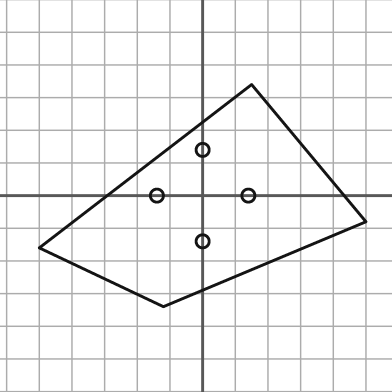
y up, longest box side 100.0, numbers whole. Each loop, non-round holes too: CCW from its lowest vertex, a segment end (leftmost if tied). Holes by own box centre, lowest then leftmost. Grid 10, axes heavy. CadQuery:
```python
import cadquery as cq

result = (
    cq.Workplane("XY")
    .moveTo(-12.0, -34.0)
    .lineTo(50.0, -8.0)
    .lineTo(15.0, 34.0)
    .lineTo(-50.0, -16.0)
    .close()
    .moveTo(0.0, -14.0)
    .circle(2.0)
    .moveTo(-14.0, 0.0)
    .circle(2.0)
    .moveTo(14.0, 0.0)
    .circle(2.0)
    .moveTo(0.0, 14.0)
    .circle(2.0)
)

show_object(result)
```